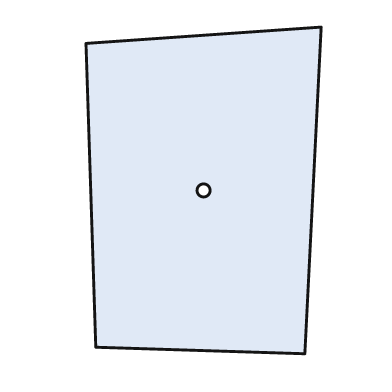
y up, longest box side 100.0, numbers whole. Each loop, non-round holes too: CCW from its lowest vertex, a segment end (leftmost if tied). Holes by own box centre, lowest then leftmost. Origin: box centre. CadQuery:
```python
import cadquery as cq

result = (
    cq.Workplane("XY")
    .moveTo(31.0, -50.0)
    .lineTo(36.0, 50.0)
    .lineTo(-36.0, 45.0)
    .lineTo(-33.0, -48.0)
    .close()
    .moveTo(0.0, 0.0)
    .circle(2.0)
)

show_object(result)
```